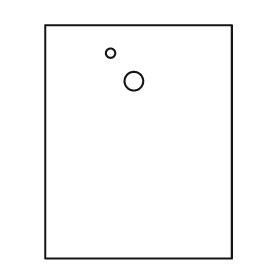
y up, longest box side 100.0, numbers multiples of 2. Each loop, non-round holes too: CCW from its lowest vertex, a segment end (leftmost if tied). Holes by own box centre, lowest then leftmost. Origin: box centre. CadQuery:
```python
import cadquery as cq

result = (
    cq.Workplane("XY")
    .moveTo(-40.0, -50.0)
    .lineTo(40.0, -50.0)
    .lineTo(40.0, 50.0)
    .lineTo(-40.0, 50.0)
    .close()
    .moveTo(-2.0, 26.0)
    .circle(4.0)
    .moveTo(-12.0, 38.0)
    .circle(2.0)
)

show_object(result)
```